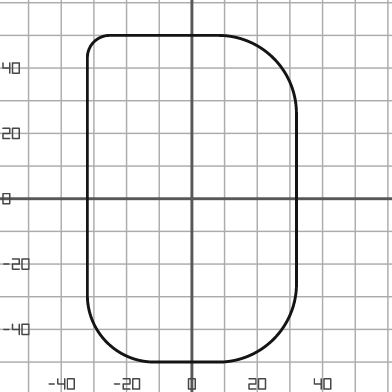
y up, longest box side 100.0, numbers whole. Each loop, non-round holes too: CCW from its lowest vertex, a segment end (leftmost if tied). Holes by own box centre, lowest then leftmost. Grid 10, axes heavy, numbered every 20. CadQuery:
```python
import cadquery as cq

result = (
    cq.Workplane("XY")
    .moveTo(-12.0, -50.0)
    .lineTo(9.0, -50.0)
    .threePointArc((25.0, -43.0), (32.0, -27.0))
    .lineTo(32.0, 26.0)
    .threePointArc((25.0, 43.0), (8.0, 50.0))
    .lineTo(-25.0, 50.0)
    .threePointArc((-30.0, 48.0), (-32.0, 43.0))
    .lineTo(-32.0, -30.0)
    .threePointArc((-26.0, -44.0), (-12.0, -50.0))
    .close()
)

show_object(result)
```